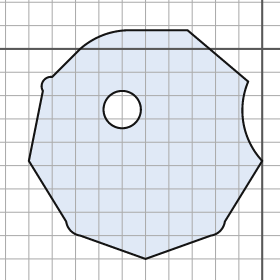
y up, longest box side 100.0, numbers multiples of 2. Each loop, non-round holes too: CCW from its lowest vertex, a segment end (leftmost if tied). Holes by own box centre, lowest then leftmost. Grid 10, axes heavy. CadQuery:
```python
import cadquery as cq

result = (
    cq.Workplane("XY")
    .moveTo(-50.0, -90.0)
    .lineTo(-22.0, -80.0)
    .threePointArc((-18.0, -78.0), (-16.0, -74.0))
    .lineTo(0.0, -48.0)
    .threePointArc((-8.0, -32.0), (-6.0, -14.0))
    .lineTo(-32.0, 8.0)
    .lineTo(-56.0, 8.0)
    .threePointArc((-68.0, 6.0), (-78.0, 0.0))
    .lineTo(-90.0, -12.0)
    .threePointArc((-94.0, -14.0), (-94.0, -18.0))
    .lineTo(-100.0, -48.0)
    .lineTo(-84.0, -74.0)
    .threePointArc((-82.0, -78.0), (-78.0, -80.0))
    .close()
    .moveTo(-60.0, -26.0)
    .circle(8.0)
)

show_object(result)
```